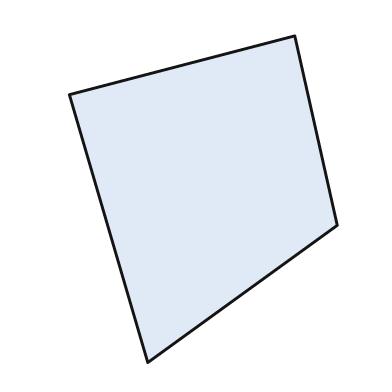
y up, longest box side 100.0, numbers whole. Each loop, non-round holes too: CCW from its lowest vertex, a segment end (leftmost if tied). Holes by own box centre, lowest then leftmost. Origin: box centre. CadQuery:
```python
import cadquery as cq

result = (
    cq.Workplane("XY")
    .moveTo(-17.0, -50.0)
    .lineTo(41.0, -8.0)
    .lineTo(28.0, 50.0)
    .lineTo(-41.0, 32.0)
    .close()
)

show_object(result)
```